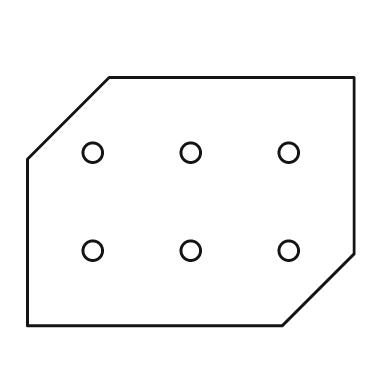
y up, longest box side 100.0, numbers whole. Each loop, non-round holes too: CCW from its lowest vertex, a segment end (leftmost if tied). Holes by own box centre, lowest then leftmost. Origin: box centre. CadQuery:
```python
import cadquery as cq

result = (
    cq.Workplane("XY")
    .moveTo(-50.0, -38.0)
    .lineTo(28.0, -38.0)
    .lineTo(50.0, -16.0)
    .lineTo(50.0, 38.0)
    .lineTo(-25.0, 38.0)
    .lineTo(-50.0, 13.0)
    .close()
    .moveTo(-30.0, -15.0)
    .circle(3.0)
    .moveTo(0.0, -15.0)
    .circle(3.0)
    .moveTo(30.0, -15.0)
    .circle(3.0)
    .moveTo(-30.0, 15.0)
    .circle(3.0)
    .moveTo(0.0, 15.0)
    .circle(3.0)
    .moveTo(30.0, 15.0)
    .circle(3.0)
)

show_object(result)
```